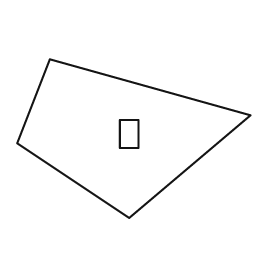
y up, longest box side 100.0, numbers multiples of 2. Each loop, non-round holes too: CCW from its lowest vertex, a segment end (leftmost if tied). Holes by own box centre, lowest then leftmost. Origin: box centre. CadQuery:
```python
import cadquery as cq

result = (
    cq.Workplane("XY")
    .moveTo(-2.0, -34.0)
    .lineTo(50.0, 10.0)
    .lineTo(-36.0, 34.0)
    .lineTo(-50.0, -2.0)
    .close()
    .moveTo(-6.0, -4.0)
    .lineTo(2.0, -4.0)
    .lineTo(2.0, 8.0)
    .lineTo(-6.0, 8.0)
    .close()
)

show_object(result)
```